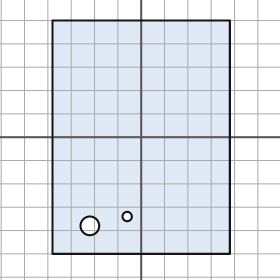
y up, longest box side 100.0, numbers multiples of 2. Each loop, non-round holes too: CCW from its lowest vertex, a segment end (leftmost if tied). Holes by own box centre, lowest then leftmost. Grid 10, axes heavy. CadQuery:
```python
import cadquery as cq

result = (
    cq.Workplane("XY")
    .moveTo(-38.0, -50.0)
    .lineTo(38.0, -50.0)
    .lineTo(38.0, 50.0)
    .lineTo(-38.0, 50.0)
    .close()
    .moveTo(-22.0, -38.0)
    .circle(4.0)
    .moveTo(-6.0, -34.0)
    .circle(2.0)
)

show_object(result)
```